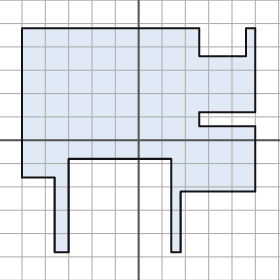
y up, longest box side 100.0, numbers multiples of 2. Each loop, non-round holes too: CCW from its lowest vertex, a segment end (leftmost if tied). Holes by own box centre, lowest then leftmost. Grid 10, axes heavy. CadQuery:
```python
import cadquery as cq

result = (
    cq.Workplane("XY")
    .moveTo(-36.0, -48.0)
    .lineTo(-30.0, -48.0)
    .lineTo(-30.0, -8.0)
    .lineTo(14.0, -8.0)
    .lineTo(14.0, -48.0)
    .lineTo(18.0, -48.0)
    .lineTo(18.0, -22.0)
    .lineTo(50.0, -22.0)
    .lineTo(50.0, 6.0)
    .lineTo(26.0, 6.0)
    .lineTo(26.0, 12.0)
    .lineTo(50.0, 12.0)
    .lineTo(50.0, 48.0)
    .lineTo(46.0, 48.0)
    .lineTo(46.0, 36.0)
    .lineTo(26.0, 36.0)
    .lineTo(26.0, 48.0)
    .lineTo(-50.0, 48.0)
    .lineTo(-50.0, -16.0)
    .lineTo(-36.0, -16.0)
    .close()
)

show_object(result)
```